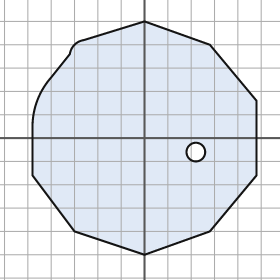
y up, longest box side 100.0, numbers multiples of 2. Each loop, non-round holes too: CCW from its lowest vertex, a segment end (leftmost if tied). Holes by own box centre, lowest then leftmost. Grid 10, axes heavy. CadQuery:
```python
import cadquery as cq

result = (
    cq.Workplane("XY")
    .moveTo(0.0, -50.0)
    .lineTo(28.0, -40.0)
    .lineTo(48.0, -16.0)
    .lineTo(48.0, 16.0)
    .lineTo(28.0, 40.0)
    .lineTo(0.0, 50.0)
    .lineTo(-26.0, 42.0)
    .threePointArc((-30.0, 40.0), (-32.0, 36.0))
    .lineTo(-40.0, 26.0)
    .threePointArc((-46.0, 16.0), (-48.0, 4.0))
    .lineTo(-48.0, -16.0)
    .lineTo(-30.0, -40.0)
    .close()
    .moveTo(22.0, -6.0)
    .circle(4.0)
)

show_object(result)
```